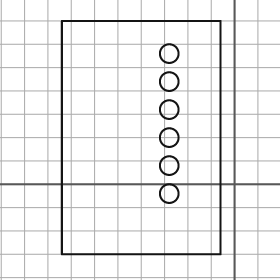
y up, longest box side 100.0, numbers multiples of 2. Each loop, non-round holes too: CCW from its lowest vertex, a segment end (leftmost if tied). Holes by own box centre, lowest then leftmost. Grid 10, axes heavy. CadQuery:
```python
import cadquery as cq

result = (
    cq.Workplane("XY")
    .moveTo(-74.0, -30.0)
    .lineTo(-6.0, -30.0)
    .lineTo(-6.0, 70.0)
    .lineTo(-74.0, 70.0)
    .close()
    .moveTo(-28.0, -4.0)
    .circle(4.0)
    .moveTo(-28.0, 8.0)
    .circle(4.0)
    .moveTo(-28.0, 20.0)
    .circle(4.0)
    .moveTo(-28.0, 32.0)
    .circle(4.0)
    .moveTo(-28.0, 44.0)
    .circle(4.0)
    .moveTo(-28.0, 56.0)
    .circle(4.0)
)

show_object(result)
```